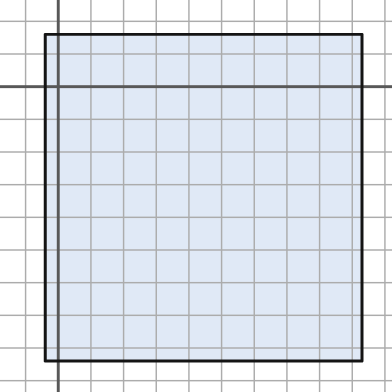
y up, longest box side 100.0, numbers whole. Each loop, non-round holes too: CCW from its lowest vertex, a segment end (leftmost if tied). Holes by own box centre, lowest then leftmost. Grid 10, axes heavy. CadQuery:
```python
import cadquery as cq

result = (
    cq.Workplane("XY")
    .moveTo(-4.0, -84.0)
    .lineTo(93.0, -84.0)
    .lineTo(93.0, 16.0)
    .lineTo(-4.0, 16.0)
    .close()
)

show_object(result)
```